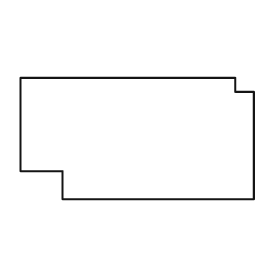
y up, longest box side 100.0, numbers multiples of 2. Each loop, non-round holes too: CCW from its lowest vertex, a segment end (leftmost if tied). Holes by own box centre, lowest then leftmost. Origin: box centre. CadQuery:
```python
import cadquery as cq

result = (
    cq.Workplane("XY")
    .moveTo(-32.0, -26.0)
    .lineTo(50.0, -26.0)
    .lineTo(50.0, 20.0)
    .lineTo(42.0, 20.0)
    .lineTo(42.0, 26.0)
    .lineTo(-50.0, 26.0)
    .lineTo(-50.0, -14.0)
    .lineTo(-32.0, -14.0)
    .close()
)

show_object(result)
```